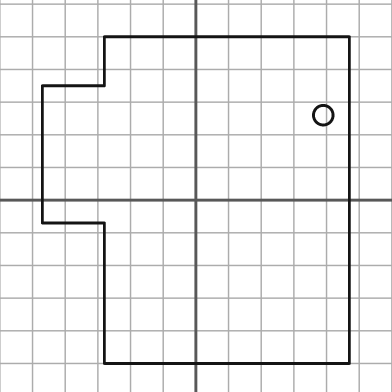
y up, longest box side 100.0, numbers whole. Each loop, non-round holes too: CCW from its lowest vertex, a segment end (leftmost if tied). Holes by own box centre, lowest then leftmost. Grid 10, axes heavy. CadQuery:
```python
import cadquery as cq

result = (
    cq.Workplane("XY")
    .moveTo(-28.0, -50.0)
    .lineTo(47.0, -50.0)
    .lineTo(47.0, 50.0)
    .lineTo(-28.0, 50.0)
    .lineTo(-28.0, 35.0)
    .lineTo(-47.0, 35.0)
    .lineTo(-47.0, -7.0)
    .lineTo(-28.0, -7.0)
    .close()
    .moveTo(39.0, 26.0)
    .circle(3.0)
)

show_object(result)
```